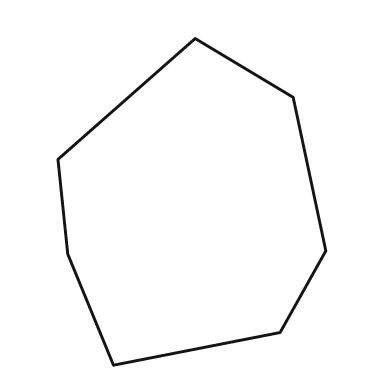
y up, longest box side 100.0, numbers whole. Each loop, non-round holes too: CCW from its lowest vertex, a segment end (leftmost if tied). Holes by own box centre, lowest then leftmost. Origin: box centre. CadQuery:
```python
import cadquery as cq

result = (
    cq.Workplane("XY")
    .moveTo(-24.0, -50.0)
    .lineTo(27.0, -40.0)
    .lineTo(41.0, -15.0)
    .lineTo(31.0, 32.0)
    .lineTo(1.0, 50.0)
    .lineTo(-41.0, 13.0)
    .lineTo(-38.0, -16.0)
    .close()
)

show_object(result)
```